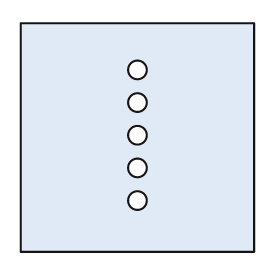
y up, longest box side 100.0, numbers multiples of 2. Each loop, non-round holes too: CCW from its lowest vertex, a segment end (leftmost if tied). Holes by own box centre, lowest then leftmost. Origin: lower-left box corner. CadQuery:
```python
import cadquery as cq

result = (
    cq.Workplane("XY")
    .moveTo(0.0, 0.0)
    .lineTo(100.0, 0.0)
    .lineTo(100.0, 98.0)
    .lineTo(0.0, 98.0)
    .close()
    .moveTo(50.0, 22.0)
    .circle(4.0)
    .moveTo(50.0, 36.0)
    .circle(4.0)
    .moveTo(50.0, 50.0)
    .circle(4.0)
    .moveTo(50.0, 64.0)
    .circle(4.0)
    .moveTo(50.0, 78.0)
    .circle(4.0)
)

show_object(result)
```